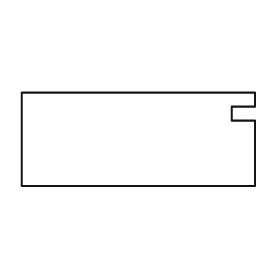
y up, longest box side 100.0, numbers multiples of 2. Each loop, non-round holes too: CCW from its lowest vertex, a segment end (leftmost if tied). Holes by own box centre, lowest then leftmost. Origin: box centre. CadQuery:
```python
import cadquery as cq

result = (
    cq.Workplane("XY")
    .moveTo(-50.0, -20.0)
    .lineTo(50.0, -20.0)
    .lineTo(50.0, 8.0)
    .lineTo(40.0, 8.0)
    .lineTo(40.0, 14.0)
    .lineTo(50.0, 14.0)
    .lineTo(50.0, 20.0)
    .lineTo(-50.0, 20.0)
    .close()
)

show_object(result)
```